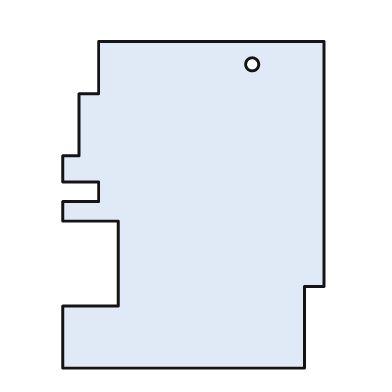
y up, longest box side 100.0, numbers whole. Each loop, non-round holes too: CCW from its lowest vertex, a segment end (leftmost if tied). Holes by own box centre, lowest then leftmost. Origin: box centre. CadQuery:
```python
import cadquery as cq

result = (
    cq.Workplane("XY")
    .moveTo(-40.0, -50.0)
    .lineTo(34.0, -50.0)
    .lineTo(34.0, -25.0)
    .lineTo(40.0, -25.0)
    .lineTo(40.0, 50.0)
    .lineTo(-29.0, 50.0)
    .lineTo(-29.0, 34.0)
    .lineTo(-35.0, 34.0)
    .lineTo(-35.0, 15.0)
    .lineTo(-40.0, 15.0)
    .lineTo(-40.0, 7.0)
    .lineTo(-29.0, 7.0)
    .lineTo(-29.0, 1.0)
    .lineTo(-40.0, 1.0)
    .lineTo(-40.0, -5.0)
    .lineTo(-23.0, -5.0)
    .lineTo(-23.0, -31.0)
    .lineTo(-40.0, -31.0)
    .close()
    .moveTo(18.0, 43.0)
    .circle(2.0)
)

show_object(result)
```